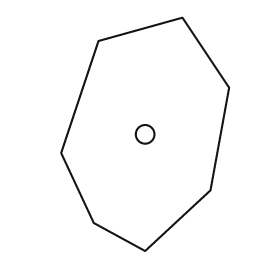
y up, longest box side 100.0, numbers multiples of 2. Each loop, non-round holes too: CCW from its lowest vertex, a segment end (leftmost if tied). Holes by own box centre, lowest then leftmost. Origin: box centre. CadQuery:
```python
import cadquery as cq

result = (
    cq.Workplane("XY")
    .moveTo(0.0, -50.0)
    .lineTo(28.0, -24.0)
    .lineTo(36.0, 20.0)
    .lineTo(16.0, 50.0)
    .lineTo(-20.0, 40.0)
    .lineTo(-36.0, -8.0)
    .lineTo(-22.0, -38.0)
    .close()
    .moveTo(0.0, 0.0)
    .circle(4.0)
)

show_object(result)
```